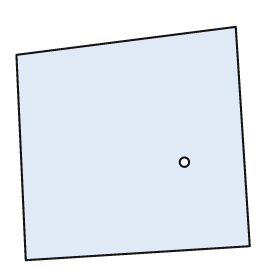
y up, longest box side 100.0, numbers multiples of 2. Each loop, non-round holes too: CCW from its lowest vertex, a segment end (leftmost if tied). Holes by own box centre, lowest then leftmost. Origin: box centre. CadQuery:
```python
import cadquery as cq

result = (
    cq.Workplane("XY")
    .moveTo(-46.0, -50.0)
    .lineTo(50.0, -44.0)
    .lineTo(44.0, 50.0)
    .lineTo(-50.0, 38.0)
    .close()
    .moveTo(22.0, -8.0)
    .circle(2.0)
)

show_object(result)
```